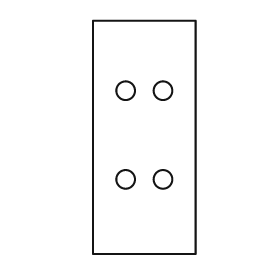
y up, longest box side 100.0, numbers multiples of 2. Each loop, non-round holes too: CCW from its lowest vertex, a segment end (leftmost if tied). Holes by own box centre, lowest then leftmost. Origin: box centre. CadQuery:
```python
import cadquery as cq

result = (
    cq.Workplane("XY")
    .moveTo(-22.0, -50.0)
    .lineTo(22.0, -50.0)
    .lineTo(22.0, 50.0)
    .lineTo(-22.0, 50.0)
    .close()
    .moveTo(-8.0, -18.0)
    .circle(4.0)
    .moveTo(8.0, -18.0)
    .circle(4.0)
    .moveTo(-8.0, 20.0)
    .circle(4.0)
    .moveTo(8.0, 20.0)
    .circle(4.0)
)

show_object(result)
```